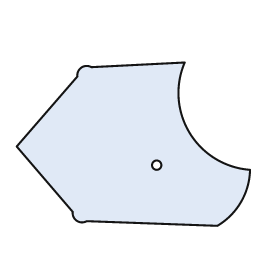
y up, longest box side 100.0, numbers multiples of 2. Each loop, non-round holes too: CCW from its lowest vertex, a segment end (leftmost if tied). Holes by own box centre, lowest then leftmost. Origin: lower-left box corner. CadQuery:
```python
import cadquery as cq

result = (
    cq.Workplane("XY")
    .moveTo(86.0, 0.0)
    .threePointArc((96.0, 10.0), (100.0, 24.0))
    .threePointArc((74.0, 40.0), (72.0, 70.0))
    .lineTo(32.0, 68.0)
    .threePointArc((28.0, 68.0), (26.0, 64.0))
    .lineTo(0.0, 34.0)
    .lineTo(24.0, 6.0)
    .threePointArc((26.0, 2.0), (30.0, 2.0))
    .close()
    .moveTo(60.0, 26.0)
    .circle(2.0)
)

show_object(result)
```